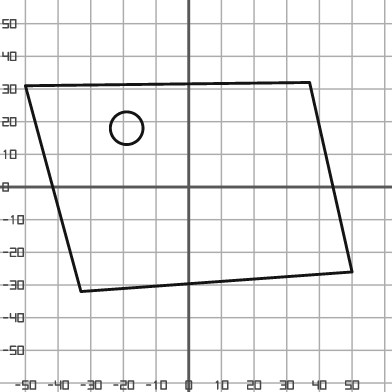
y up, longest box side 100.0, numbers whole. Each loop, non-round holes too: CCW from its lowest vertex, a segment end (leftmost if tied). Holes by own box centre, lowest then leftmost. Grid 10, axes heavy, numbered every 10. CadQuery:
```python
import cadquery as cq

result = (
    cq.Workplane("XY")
    .moveTo(-33.0, -32.0)
    .lineTo(50.0, -26.0)
    .lineTo(37.0, 32.0)
    .lineTo(-50.0, 31.0)
    .close()
    .moveTo(-19.0, 18.0)
    .circle(5.0)
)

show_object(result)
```